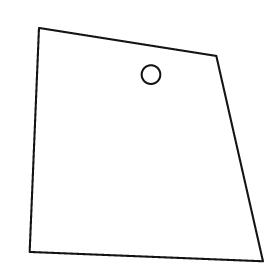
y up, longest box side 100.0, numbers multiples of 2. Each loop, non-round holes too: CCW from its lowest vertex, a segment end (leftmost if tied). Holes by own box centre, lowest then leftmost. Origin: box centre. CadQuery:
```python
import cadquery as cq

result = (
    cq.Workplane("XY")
    .moveTo(50.0, -50.0)
    .lineTo(30.0, 38.0)
    .lineTo(-46.0, 50.0)
    .lineTo(-50.0, -46.0)
    .close()
    .moveTo(2.0, 30.0)
    .circle(4.0)
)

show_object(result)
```